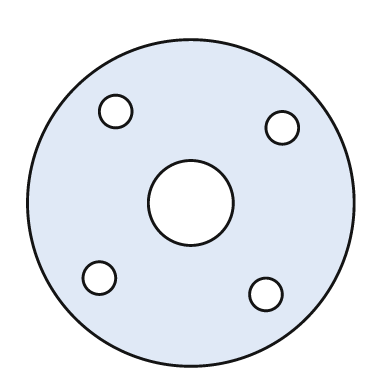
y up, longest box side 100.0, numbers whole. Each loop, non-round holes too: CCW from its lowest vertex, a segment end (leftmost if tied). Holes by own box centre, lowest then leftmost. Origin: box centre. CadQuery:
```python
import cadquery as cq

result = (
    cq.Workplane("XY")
    .moveTo(0.0, 0.0)
    .circle(50.0)
    .moveTo(23.0, -28.0)
    .circle(5.0)
    .moveTo(-28.0, -23.0)
    .circle(5.0)
    .moveTo(0.0, 0.0)
    .circle(13.0)
    .moveTo(28.0, 23.0)
    .circle(5.0)
    .moveTo(-23.0, 28.0)
    .circle(5.0)
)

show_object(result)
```